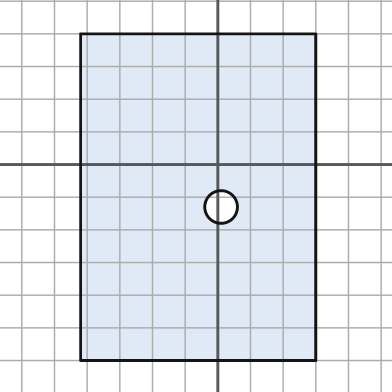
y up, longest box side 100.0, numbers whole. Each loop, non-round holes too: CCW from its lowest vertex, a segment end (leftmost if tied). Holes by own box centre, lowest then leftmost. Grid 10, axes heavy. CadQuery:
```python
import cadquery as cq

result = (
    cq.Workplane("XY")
    .moveTo(-42.0, -60.0)
    .lineTo(30.0, -60.0)
    .lineTo(30.0, 40.0)
    .lineTo(-42.0, 40.0)
    .close()
    .moveTo(1.0, -13.0)
    .circle(5.0)
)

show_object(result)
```